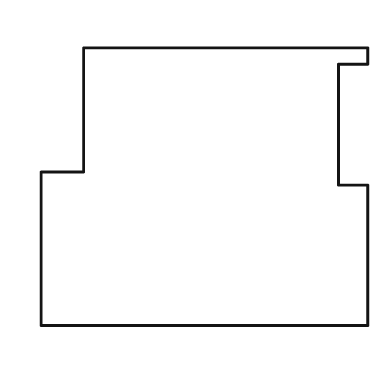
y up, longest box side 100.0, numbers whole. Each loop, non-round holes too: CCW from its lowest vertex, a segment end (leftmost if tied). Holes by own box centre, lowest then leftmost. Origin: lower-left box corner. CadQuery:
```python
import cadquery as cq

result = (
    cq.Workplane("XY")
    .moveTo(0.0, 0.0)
    .lineTo(100.0, 0.0)
    .lineTo(100.0, 43.0)
    .lineTo(91.0, 43.0)
    .lineTo(91.0, 80.0)
    .lineTo(100.0, 80.0)
    .lineTo(100.0, 85.0)
    .lineTo(13.0, 85.0)
    .lineTo(13.0, 47.0)
    .lineTo(0.0, 47.0)
    .close()
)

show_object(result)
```